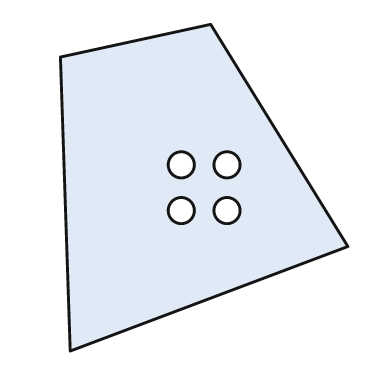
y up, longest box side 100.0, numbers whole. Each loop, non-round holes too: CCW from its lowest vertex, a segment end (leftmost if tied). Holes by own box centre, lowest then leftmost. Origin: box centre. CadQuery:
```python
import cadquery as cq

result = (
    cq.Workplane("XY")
    .moveTo(-41.0, -50.0)
    .lineTo(44.0, -18.0)
    .lineTo(2.0, 50.0)
    .lineTo(-44.0, 40.0)
    .close()
    .moveTo(-7.0, -7.0)
    .circle(4.0)
    .moveTo(7.0, -7.0)
    .circle(4.0)
    .moveTo(-7.0, 7.0)
    .circle(4.0)
    .moveTo(7.0, 7.0)
    .circle(4.0)
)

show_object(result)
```